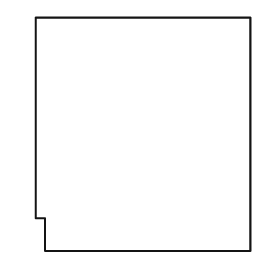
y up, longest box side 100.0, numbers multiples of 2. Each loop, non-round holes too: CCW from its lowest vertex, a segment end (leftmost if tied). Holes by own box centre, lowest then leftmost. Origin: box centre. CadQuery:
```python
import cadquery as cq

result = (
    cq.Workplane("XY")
    .moveTo(-42.0, -50.0)
    .lineTo(46.0, -50.0)
    .lineTo(46.0, 50.0)
    .lineTo(-46.0, 50.0)
    .lineTo(-46.0, -36.0)
    .lineTo(-42.0, -36.0)
    .close()
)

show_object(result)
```